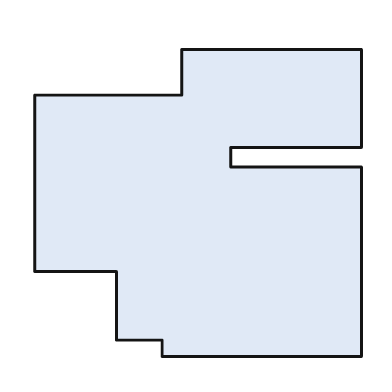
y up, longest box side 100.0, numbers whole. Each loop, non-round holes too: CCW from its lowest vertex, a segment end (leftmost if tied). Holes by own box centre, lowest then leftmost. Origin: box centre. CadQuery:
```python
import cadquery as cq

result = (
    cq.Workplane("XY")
    .moveTo(-11.0, -47.0)
    .lineTo(50.0, -47.0)
    .lineTo(50.0, 11.0)
    .lineTo(10.0, 11.0)
    .lineTo(10.0, 17.0)
    .lineTo(50.0, 17.0)
    .lineTo(50.0, 47.0)
    .lineTo(-5.0, 47.0)
    .lineTo(-5.0, 33.0)
    .lineTo(-50.0, 33.0)
    .lineTo(-50.0, -21.0)
    .lineTo(-25.0, -21.0)
    .lineTo(-25.0, -42.0)
    .lineTo(-11.0, -42.0)
    .close()
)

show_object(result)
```